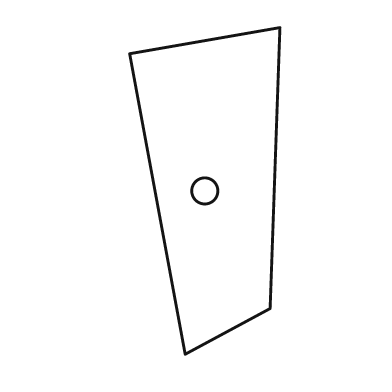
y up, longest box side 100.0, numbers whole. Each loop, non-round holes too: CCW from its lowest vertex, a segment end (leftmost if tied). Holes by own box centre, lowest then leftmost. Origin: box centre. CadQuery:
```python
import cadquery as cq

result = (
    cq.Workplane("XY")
    .moveTo(-6.0, -50.0)
    .lineTo(20.0, -36.0)
    .lineTo(23.0, 50.0)
    .lineTo(-23.0, 42.0)
    .close()
    .moveTo(0.0, 0.0)
    .circle(4.0)
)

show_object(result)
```